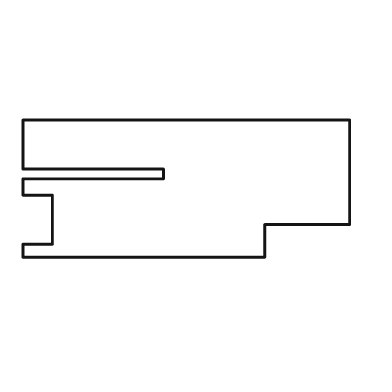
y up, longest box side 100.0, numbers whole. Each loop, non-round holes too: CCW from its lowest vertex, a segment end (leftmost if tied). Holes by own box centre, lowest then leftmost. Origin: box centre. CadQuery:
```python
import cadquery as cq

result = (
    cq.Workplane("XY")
    .moveTo(-50.0, -21.0)
    .lineTo(24.0, -21.0)
    .lineTo(24.0, -11.0)
    .lineTo(50.0, -11.0)
    .lineTo(50.0, 21.0)
    .lineTo(-50.0, 21.0)
    .lineTo(-50.0, 6.0)
    .lineTo(-7.0, 6.0)
    .lineTo(-7.0, 3.0)
    .lineTo(-50.0, 3.0)
    .lineTo(-50.0, -2.0)
    .lineTo(-41.0, -2.0)
    .lineTo(-41.0, -17.0)
    .lineTo(-50.0, -17.0)
    .close()
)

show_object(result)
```